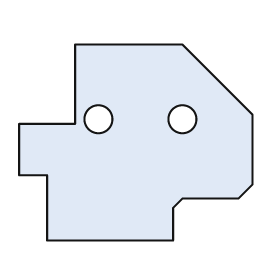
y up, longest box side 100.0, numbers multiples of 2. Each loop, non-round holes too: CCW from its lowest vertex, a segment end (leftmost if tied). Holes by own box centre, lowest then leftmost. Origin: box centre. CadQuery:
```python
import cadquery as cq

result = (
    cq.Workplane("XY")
    .moveTo(-38.0, -42.0)
    .lineTo(16.0, -42.0)
    .lineTo(16.0, -28.0)
    .lineTo(20.0, -24.0)
    .lineTo(44.0, -24.0)
    .lineTo(50.0, -18.0)
    .lineTo(50.0, 12.0)
    .lineTo(20.0, 42.0)
    .lineTo(-26.0, 42.0)
    .lineTo(-26.0, 8.0)
    .lineTo(-50.0, 8.0)
    .lineTo(-50.0, -14.0)
    .lineTo(-38.0, -14.0)
    .close()
    .moveTo(-16.0, 10.0)
    .circle(6.0)
    .moveTo(20.0, 10.0)
    .circle(6.0)
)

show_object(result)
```